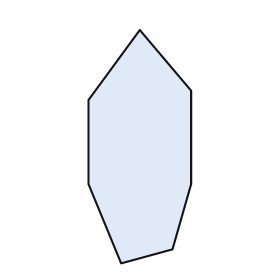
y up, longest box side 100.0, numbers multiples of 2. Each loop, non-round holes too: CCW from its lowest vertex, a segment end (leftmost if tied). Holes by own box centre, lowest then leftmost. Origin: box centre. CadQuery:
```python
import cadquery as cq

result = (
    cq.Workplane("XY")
    .moveTo(-8.0, -50.0)
    .lineTo(14.0, -44.0)
    .lineTo(22.0, -16.0)
    .lineTo(22.0, 24.0)
    .lineTo(0.0, 50.0)
    .lineTo(-22.0, 20.0)
    .lineTo(-22.0, -16.0)
    .close()
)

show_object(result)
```